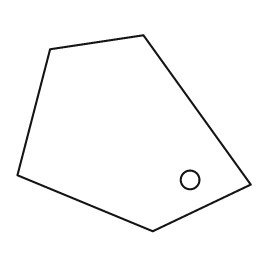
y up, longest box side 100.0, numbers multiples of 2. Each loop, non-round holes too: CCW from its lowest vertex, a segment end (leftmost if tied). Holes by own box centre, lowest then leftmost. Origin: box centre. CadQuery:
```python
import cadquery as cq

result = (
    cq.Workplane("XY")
    .moveTo(8.0, -42.0)
    .lineTo(50.0, -22.0)
    .lineTo(4.0, 42.0)
    .lineTo(-36.0, 36.0)
    .lineTo(-50.0, -18.0)
    .close()
    .moveTo(24.0, -20.0)
    .circle(4.0)
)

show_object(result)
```